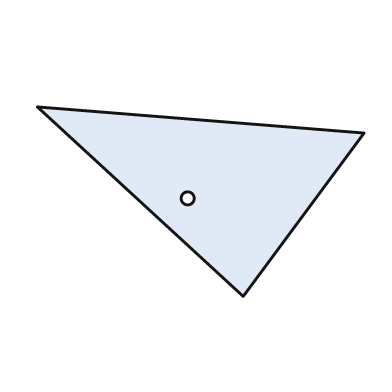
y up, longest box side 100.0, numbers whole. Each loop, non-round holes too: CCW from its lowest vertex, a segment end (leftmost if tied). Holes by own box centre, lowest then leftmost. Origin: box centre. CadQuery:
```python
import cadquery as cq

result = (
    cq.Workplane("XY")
    .moveTo(13.0, -29.0)
    .lineTo(50.0, 21.0)
    .lineTo(-50.0, 29.0)
    .close()
    .moveTo(-4.0, 1.0)
    .circle(2.0)
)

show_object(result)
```